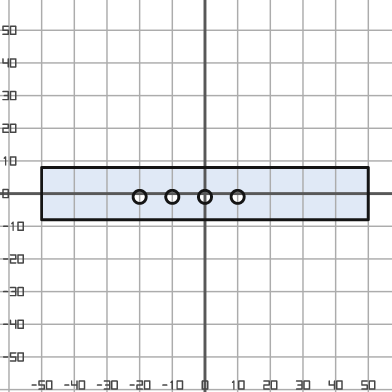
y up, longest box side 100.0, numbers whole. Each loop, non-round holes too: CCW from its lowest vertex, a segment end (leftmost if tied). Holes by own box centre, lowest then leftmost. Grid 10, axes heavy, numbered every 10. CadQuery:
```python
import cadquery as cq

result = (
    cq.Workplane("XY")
    .moveTo(-50.0, -8.0)
    .lineTo(50.0, -8.0)
    .lineTo(50.0, 8.0)
    .lineTo(-50.0, 8.0)
    .close()
    .moveTo(-20.0, -1.0)
    .circle(2.0)
    .moveTo(-10.0, -1.0)
    .circle(2.0)
    .moveTo(0.0, -1.0)
    .circle(2.0)
    .moveTo(10.0, -1.0)
    .circle(2.0)
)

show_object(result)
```